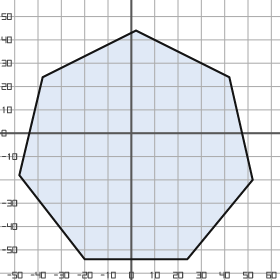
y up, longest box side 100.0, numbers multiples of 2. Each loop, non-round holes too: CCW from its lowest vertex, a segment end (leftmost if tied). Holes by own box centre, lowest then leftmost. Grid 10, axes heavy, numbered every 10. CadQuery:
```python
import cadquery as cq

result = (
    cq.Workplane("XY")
    .moveTo(-20.0, -54.0)
    .lineTo(24.0, -54.0)
    .lineTo(52.0, -20.0)
    .lineTo(42.0, 24.0)
    .lineTo(2.0, 44.0)
    .lineTo(-38.0, 24.0)
    .lineTo(-48.0, -18.0)
    .close()
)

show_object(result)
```